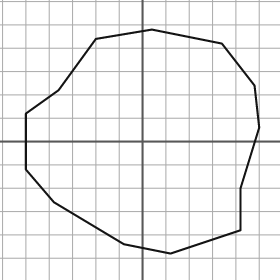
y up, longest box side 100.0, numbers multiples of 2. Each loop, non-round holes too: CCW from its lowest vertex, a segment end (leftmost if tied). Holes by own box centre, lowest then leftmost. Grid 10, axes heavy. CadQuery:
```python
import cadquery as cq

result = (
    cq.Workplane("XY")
    .moveTo(12.0, -48.0)
    .lineTo(42.0, -38.0)
    .lineTo(42.0, -20.0)
    .lineTo(50.0, 6.0)
    .lineTo(48.0, 24.0)
    .lineTo(34.0, 42.0)
    .lineTo(4.0, 48.0)
    .lineTo(-20.0, 44.0)
    .lineTo(-36.0, 22.0)
    .lineTo(-50.0, 12.0)
    .lineTo(-50.0, -12.0)
    .lineTo(-38.0, -26.0)
    .lineTo(-8.0, -44.0)
    .close()
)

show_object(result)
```